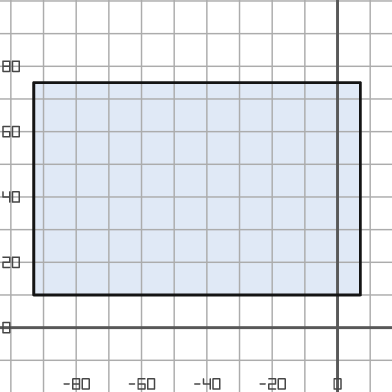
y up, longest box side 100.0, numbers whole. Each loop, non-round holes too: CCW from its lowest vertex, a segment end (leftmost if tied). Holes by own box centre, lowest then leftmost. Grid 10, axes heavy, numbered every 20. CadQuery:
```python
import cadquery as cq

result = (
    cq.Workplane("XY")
    .moveTo(-93.0, 10.0)
    .lineTo(7.0, 10.0)
    .lineTo(7.0, 75.0)
    .lineTo(-93.0, 75.0)
    .close()
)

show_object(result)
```